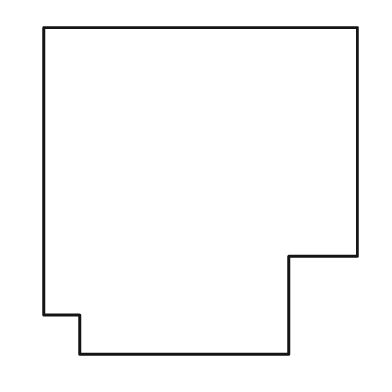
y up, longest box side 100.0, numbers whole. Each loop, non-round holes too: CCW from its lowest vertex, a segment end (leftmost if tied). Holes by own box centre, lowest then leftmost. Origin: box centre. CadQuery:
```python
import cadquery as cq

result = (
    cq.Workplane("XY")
    .moveTo(-37.0, -50.0)
    .lineTo(27.0, -50.0)
    .lineTo(27.0, -20.0)
    .lineTo(48.0, -20.0)
    .lineTo(48.0, 50.0)
    .lineTo(-48.0, 50.0)
    .lineTo(-48.0, -38.0)
    .lineTo(-37.0, -38.0)
    .close()
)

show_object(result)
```